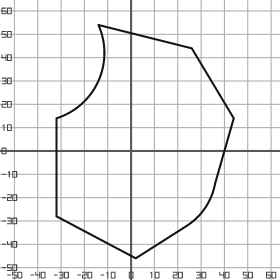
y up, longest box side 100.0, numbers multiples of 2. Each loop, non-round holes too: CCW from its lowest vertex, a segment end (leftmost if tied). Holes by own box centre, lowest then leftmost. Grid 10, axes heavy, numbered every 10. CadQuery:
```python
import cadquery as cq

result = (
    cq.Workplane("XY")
    .moveTo(2.0, -46.0)
    .lineTo(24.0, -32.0)
    .threePointArc((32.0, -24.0), (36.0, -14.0))
    .lineTo(44.0, 14.0)
    .lineTo(26.0, 44.0)
    .lineTo(-14.0, 54.0)
    .threePointArc((-14.0, 30.0), (-32.0, 14.0))
    .lineTo(-32.0, -28.0)
    .close()
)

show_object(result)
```